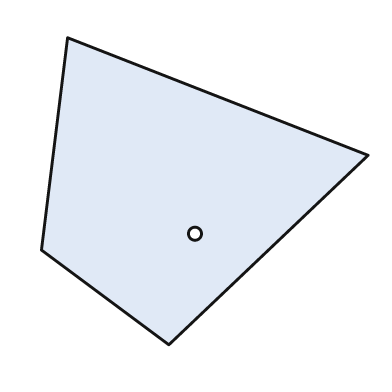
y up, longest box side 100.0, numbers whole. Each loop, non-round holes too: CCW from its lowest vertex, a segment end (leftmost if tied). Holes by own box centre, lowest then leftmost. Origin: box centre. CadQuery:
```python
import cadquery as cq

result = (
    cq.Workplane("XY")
    .moveTo(-11.0, -47.0)
    .lineTo(50.0, 11.0)
    .lineTo(-42.0, 47.0)
    .lineTo(-50.0, -18.0)
    .close()
    .moveTo(-3.0, -13.0)
    .circle(2.0)
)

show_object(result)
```